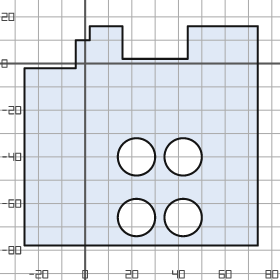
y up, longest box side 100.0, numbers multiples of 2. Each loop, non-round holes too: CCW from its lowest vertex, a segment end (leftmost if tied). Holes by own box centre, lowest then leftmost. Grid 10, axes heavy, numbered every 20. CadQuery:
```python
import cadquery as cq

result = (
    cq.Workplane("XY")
    .moveTo(-26.0, -78.0)
    .lineTo(74.0, -78.0)
    .lineTo(74.0, 16.0)
    .lineTo(44.0, 16.0)
    .lineTo(44.0, 2.0)
    .lineTo(16.0, 2.0)
    .lineTo(16.0, 16.0)
    .lineTo(2.0, 16.0)
    .lineTo(2.0, 10.0)
    .lineTo(-4.0, 10.0)
    .lineTo(-4.0, -2.0)
    .lineTo(-26.0, -2.0)
    .close()
    .moveTo(22.0, -66.0)
    .circle(8.0)
    .moveTo(42.0, -66.0)
    .circle(8.0)
    .moveTo(22.0, -40.0)
    .circle(8.0)
    .moveTo(42.0, -40.0)
    .circle(8.0)
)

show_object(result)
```